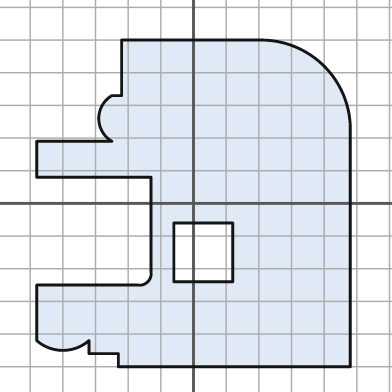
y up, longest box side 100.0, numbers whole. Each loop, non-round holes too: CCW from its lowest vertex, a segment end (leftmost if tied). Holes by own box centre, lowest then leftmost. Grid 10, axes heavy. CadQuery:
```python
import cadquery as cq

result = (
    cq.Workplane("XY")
    .moveTo(-23.0, -50.0)
    .lineTo(48.0, -50.0)
    .lineTo(48.0, 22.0)
    .threePointArc((40.0, 42.0), (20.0, 50.0))
    .lineTo(-22.0, 50.0)
    .lineTo(-22.0, 33.0)
    .lineTo(-25.0, 33.0)
    .threePointArc((-29.0, 26.0), (-25.0, 19.0))
    .lineTo(-48.0, 19.0)
    .lineTo(-48.0, 8.0)
    .lineTo(-13.0, 8.0)
    .lineTo(-13.0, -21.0)
    .threePointArc((-14.0, -24.0), (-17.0, -25.0))
    .lineTo(-48.0, -25.0)
    .lineTo(-48.0, -42.0)
    .threePointArc((-40.0, -45.0), (-32.0, -42.0))
    .lineTo(-32.0, -46.0)
    .lineTo(-23.0, -46.0)
    .close()
    .moveTo(-6.0, -24.0)
    .lineTo(12.0, -24.0)
    .lineTo(12.0, -6.0)
    .lineTo(-6.0, -6.0)
    .close()
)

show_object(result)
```